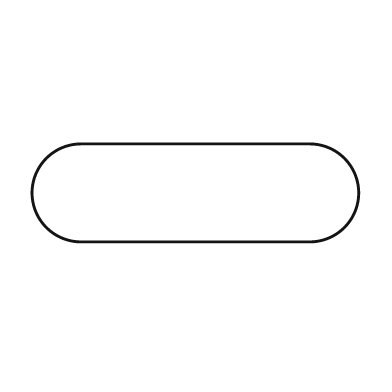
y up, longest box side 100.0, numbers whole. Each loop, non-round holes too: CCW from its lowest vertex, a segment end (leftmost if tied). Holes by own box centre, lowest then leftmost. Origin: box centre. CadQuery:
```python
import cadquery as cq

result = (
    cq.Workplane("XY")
    .moveTo(-35.0, -15.0)
    .lineTo(35.0, -15.0)
    .threePointArc((50.0, 0.0), (35.0, 15.0))
    .lineTo(-35.0, 15.0)
    .threePointArc((-50.0, 0.0), (-35.0, -15.0))
    .close()
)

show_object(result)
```